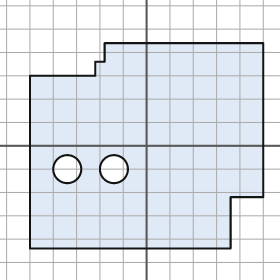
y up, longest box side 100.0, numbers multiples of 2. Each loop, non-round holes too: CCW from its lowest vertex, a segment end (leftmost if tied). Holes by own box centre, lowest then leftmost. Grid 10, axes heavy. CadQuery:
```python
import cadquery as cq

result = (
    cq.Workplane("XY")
    .moveTo(-50.0, -44.0)
    .lineTo(36.0, -44.0)
    .lineTo(36.0, -22.0)
    .lineTo(50.0, -22.0)
    .lineTo(50.0, 44.0)
    .lineTo(-18.0, 44.0)
    .lineTo(-18.0, 36.0)
    .lineTo(-22.0, 36.0)
    .lineTo(-22.0, 30.0)
    .lineTo(-50.0, 30.0)
    .close()
    .moveTo(-34.0, -10.0)
    .circle(6.0)
    .moveTo(-14.0, -10.0)
    .circle(6.0)
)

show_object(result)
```